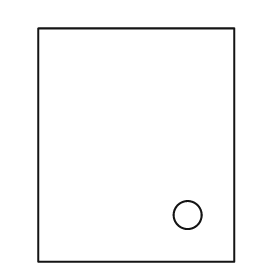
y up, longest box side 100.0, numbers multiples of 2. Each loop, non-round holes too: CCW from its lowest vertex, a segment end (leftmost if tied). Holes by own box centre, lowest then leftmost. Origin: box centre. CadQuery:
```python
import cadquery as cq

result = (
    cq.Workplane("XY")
    .moveTo(-42.0, -50.0)
    .lineTo(42.0, -50.0)
    .lineTo(42.0, 50.0)
    .lineTo(-42.0, 50.0)
    .close()
    .moveTo(22.0, -30.0)
    .circle(6.0)
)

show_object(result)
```